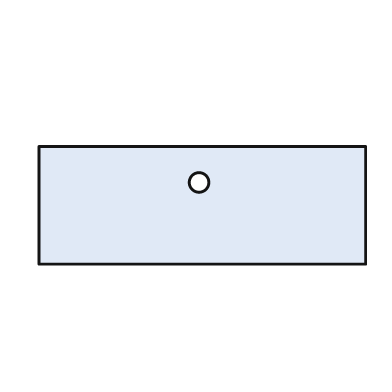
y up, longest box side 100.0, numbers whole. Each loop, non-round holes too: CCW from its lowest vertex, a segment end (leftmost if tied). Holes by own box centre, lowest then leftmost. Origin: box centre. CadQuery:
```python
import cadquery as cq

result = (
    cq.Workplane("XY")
    .moveTo(-50.0, -18.0)
    .lineTo(50.0, -18.0)
    .lineTo(50.0, 18.0)
    .lineTo(-50.0, 18.0)
    .close()
    .moveTo(-1.0, 7.0)
    .circle(3.0)
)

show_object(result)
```